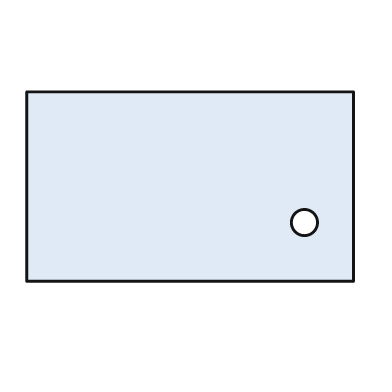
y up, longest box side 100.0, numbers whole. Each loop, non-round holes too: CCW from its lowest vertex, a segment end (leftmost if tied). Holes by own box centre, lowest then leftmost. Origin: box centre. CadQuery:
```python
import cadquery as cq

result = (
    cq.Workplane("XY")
    .moveTo(-50.0, -29.0)
    .lineTo(50.0, -29.0)
    .lineTo(50.0, 29.0)
    .lineTo(-50.0, 29.0)
    .close()
    .moveTo(35.0, -11.0)
    .circle(4.0)
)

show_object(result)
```